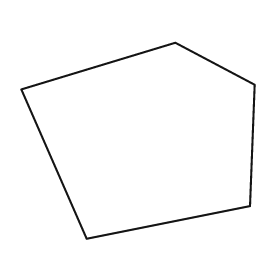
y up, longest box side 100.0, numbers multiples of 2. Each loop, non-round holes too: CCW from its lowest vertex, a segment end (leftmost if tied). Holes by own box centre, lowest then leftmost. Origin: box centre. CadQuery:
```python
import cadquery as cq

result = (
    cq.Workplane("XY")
    .moveTo(-22.0, -42.0)
    .lineTo(48.0, -28.0)
    .lineTo(50.0, 24.0)
    .lineTo(16.0, 42.0)
    .lineTo(-50.0, 22.0)
    .close()
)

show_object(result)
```